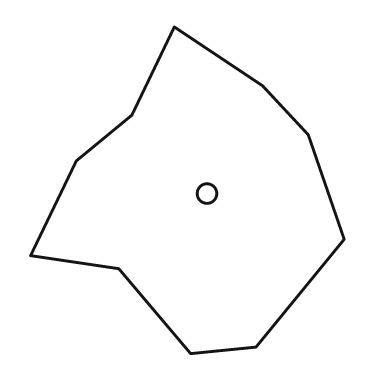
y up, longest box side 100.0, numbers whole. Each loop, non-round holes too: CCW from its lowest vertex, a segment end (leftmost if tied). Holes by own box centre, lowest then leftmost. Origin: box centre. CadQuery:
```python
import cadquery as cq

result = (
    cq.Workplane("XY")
    .moveTo(1.0, -50.0)
    .lineTo(21.0, -48.0)
    .lineTo(48.0, -15.0)
    .lineTo(37.0, 17.0)
    .lineTo(23.0, 32.0)
    .lineTo(-4.0, 50.0)
    .lineTo(-17.0, 23.0)
    .lineTo(-34.0, 9.0)
    .lineTo(-48.0, -20.0)
    .lineTo(-21.0, -24.0)
    .close()
    .moveTo(6.0, -1.0)
    .circle(3.0)
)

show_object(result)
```